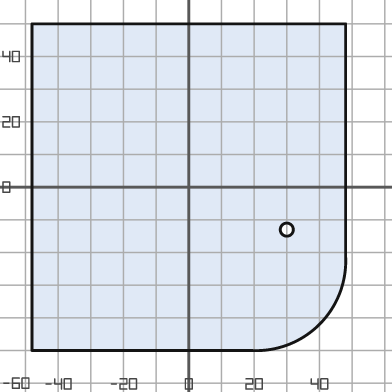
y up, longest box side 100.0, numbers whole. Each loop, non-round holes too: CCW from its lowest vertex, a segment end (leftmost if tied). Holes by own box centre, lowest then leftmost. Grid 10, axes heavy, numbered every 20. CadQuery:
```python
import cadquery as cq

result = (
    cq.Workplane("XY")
    .moveTo(-48.0, -50.0)
    .lineTo(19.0, -50.0)
    .threePointArc((40.0, -42.0), (48.0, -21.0))
    .lineTo(48.0, 50.0)
    .lineTo(-48.0, 50.0)
    .close()
    .moveTo(30.0, -13.0)
    .circle(2.0)
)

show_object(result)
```